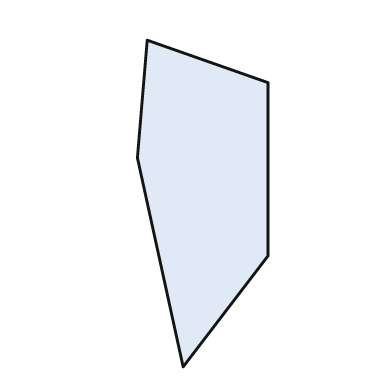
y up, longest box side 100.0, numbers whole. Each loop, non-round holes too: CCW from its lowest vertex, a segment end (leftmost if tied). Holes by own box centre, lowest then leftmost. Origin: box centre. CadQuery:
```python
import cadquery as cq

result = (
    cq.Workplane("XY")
    .moveTo(-6.0, -50.0)
    .lineTo(20.0, -16.0)
    .lineTo(20.0, 37.0)
    .lineTo(-17.0, 50.0)
    .lineTo(-20.0, 14.0)
    .close()
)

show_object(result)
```